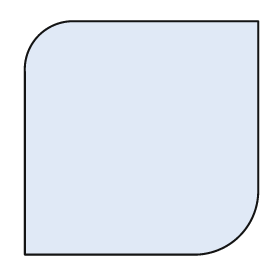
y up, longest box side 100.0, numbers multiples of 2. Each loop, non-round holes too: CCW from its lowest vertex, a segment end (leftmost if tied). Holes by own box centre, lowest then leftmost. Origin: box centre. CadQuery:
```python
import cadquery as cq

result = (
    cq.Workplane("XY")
    .moveTo(-50.0, -50.0)
    .lineTo(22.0, -50.0)
    .threePointArc((42.0, -42.0), (50.0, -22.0))
    .lineTo(50.0, 50.0)
    .lineTo(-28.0, 50.0)
    .threePointArc((-44.0, 44.0), (-50.0, 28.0))
    .close()
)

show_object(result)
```